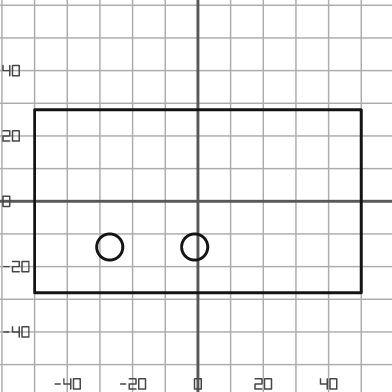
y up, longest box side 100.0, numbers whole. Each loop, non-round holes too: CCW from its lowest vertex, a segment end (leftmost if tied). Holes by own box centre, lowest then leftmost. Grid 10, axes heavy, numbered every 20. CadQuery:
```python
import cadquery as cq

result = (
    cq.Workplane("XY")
    .moveTo(-50.0, -28.0)
    .lineTo(50.0, -28.0)
    .lineTo(50.0, 28.0)
    .lineTo(-50.0, 28.0)
    .close()
    .moveTo(-27.0, -14.0)
    .circle(4.0)
    .moveTo(-1.0, -14.0)
    .circle(4.0)
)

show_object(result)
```